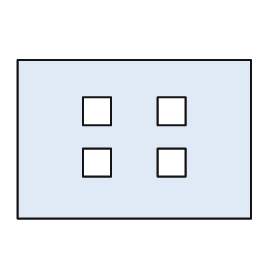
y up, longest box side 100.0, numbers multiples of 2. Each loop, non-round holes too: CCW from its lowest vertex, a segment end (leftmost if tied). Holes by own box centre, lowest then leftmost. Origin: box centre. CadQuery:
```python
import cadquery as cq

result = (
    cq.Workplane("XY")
    .moveTo(-50.0, -34.0)
    .lineTo(50.0, -34.0)
    .lineTo(50.0, 34.0)
    .lineTo(-50.0, 34.0)
    .close()
    .moveTo(-22.0, -16.0)
    .lineTo(-10.0, -16.0)
    .lineTo(-10.0, -4.0)
    .lineTo(-22.0, -4.0)
    .close()
    .moveTo(10.0, -16.0)
    .lineTo(22.0, -16.0)
    .lineTo(22.0, -4.0)
    .lineTo(10.0, -4.0)
    .close()
    .moveTo(-22.0, 6.0)
    .lineTo(-10.0, 6.0)
    .lineTo(-10.0, 18.0)
    .lineTo(-22.0, 18.0)
    .close()
    .moveTo(10.0, 6.0)
    .lineTo(22.0, 6.0)
    .lineTo(22.0, 18.0)
    .lineTo(10.0, 18.0)
    .close()
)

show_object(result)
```